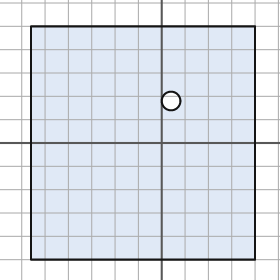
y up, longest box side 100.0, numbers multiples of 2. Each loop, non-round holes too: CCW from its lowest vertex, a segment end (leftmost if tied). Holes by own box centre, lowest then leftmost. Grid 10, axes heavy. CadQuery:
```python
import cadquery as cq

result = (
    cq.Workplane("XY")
    .moveTo(-56.0, -50.0)
    .lineTo(40.0, -50.0)
    .lineTo(40.0, 50.0)
    .lineTo(-56.0, 50.0)
    .close()
    .moveTo(4.0, 18.0)
    .circle(4.0)
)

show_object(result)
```